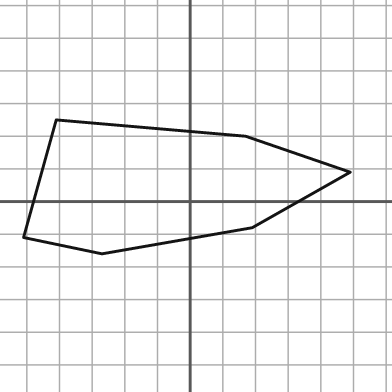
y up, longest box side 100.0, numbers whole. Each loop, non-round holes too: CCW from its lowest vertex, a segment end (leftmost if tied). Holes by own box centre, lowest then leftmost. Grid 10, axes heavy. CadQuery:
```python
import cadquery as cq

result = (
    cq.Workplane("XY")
    .moveTo(-27.0, -16.0)
    .lineTo(19.0, -8.0)
    .lineTo(49.0, 9.0)
    .lineTo(17.0, 20.0)
    .lineTo(-41.0, 25.0)
    .lineTo(-51.0, -11.0)
    .close()
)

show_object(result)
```